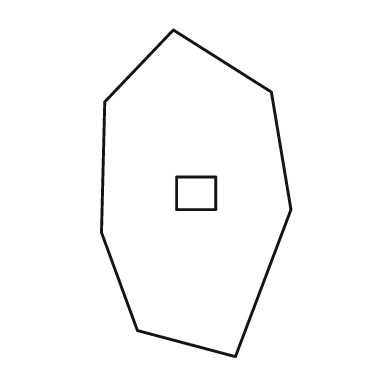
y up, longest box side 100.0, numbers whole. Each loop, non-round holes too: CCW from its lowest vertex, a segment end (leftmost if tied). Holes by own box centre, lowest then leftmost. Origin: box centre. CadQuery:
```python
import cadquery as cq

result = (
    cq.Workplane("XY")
    .moveTo(12.0, -50.0)
    .lineTo(29.0, -5.0)
    .lineTo(23.0, 31.0)
    .lineTo(-7.0, 50.0)
    .lineTo(-28.0, 28.0)
    .lineTo(-29.0, -12.0)
    .lineTo(-18.0, -42.0)
    .close()
    .moveTo(-6.0, -5.0)
    .lineTo(6.0, -5.0)
    .lineTo(6.0, 5.0)
    .lineTo(-6.0, 5.0)
    .close()
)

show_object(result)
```